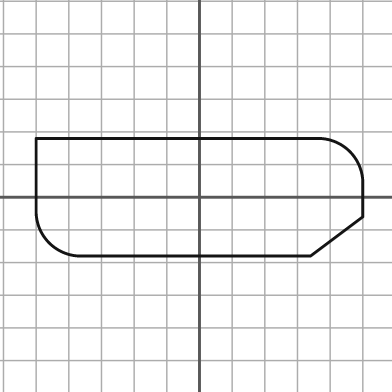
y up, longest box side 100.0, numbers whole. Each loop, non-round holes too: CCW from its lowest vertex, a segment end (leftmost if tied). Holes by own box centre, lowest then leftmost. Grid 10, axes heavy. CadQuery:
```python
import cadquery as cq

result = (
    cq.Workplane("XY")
    .moveTo(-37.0, -18.0)
    .lineTo(34.0, -18.0)
    .lineTo(50.0, -6.0)
    .lineTo(50.0, 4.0)
    .threePointArc((46.0, 14.0), (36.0, 18.0))
    .lineTo(-50.0, 18.0)
    .lineTo(-50.0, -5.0)
    .threePointArc((-46.0, -14.0), (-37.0, -18.0))
    .close()
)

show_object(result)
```